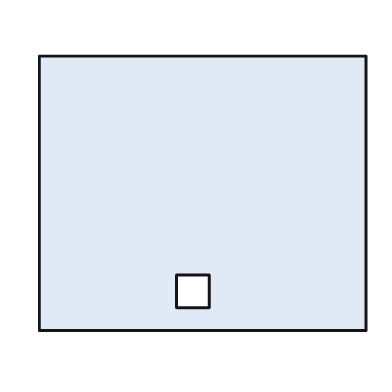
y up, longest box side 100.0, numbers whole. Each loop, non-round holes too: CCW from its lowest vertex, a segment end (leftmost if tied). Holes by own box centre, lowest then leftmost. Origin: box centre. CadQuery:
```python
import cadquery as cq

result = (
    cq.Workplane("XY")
    .moveTo(-50.0, -42.0)
    .lineTo(50.0, -42.0)
    .lineTo(50.0, 42.0)
    .lineTo(-50.0, 42.0)
    .close()
    .moveTo(-8.0, -35.0)
    .lineTo(2.0, -35.0)
    .lineTo(2.0, -25.0)
    .lineTo(-8.0, -25.0)
    .close()
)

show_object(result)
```